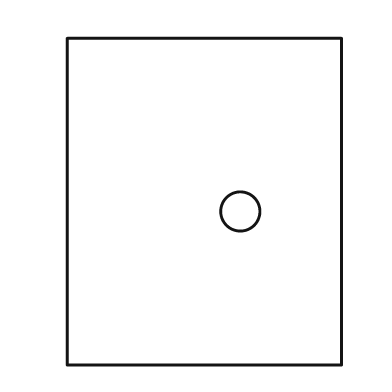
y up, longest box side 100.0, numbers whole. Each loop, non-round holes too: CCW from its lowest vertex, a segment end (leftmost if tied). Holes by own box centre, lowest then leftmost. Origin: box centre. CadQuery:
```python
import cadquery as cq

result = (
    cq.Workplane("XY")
    .moveTo(-42.0, -50.0)
    .lineTo(42.0, -50.0)
    .lineTo(42.0, 50.0)
    .lineTo(-42.0, 50.0)
    .close()
    .moveTo(11.0, -3.0)
    .circle(6.0)
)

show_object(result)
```